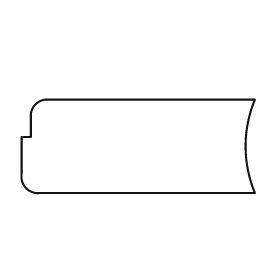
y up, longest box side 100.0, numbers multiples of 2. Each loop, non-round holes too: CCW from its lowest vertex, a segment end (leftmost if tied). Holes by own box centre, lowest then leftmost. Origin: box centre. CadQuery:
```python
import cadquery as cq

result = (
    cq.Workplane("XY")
    .moveTo(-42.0, -20.0)
    .lineTo(50.0, -20.0)
    .threePointArc((46.0, 0.0), (50.0, 20.0))
    .lineTo(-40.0, 20.0)
    .threePointArc((-44.0, 18.0), (-46.0, 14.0))
    .lineTo(-46.0, 4.0)
    .lineTo(-50.0, 4.0)
    .lineTo(-50.0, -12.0)
    .threePointArc((-48.0, -18.0), (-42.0, -20.0))
    .close()
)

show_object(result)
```